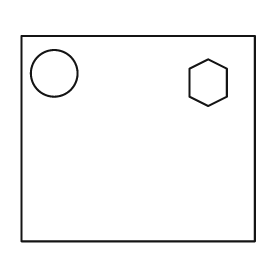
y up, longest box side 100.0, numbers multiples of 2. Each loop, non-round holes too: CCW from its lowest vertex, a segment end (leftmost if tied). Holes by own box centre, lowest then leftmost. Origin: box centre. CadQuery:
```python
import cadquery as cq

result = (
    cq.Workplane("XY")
    .moveTo(-50.0, -44.0)
    .lineTo(50.0, -44.0)
    .lineTo(50.0, 44.0)
    .lineTo(-50.0, 44.0)
    .close()
    .moveTo(30.0, 14.0)
    .lineTo(38.0, 18.0)
    .lineTo(38.0, 30.0)
    .lineTo(30.0, 34.0)
    .lineTo(22.0, 30.0)
    .lineTo(22.0, 18.0)
    .close()
    .moveTo(-36.0, 28.0)
    .circle(10.0)
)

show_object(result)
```